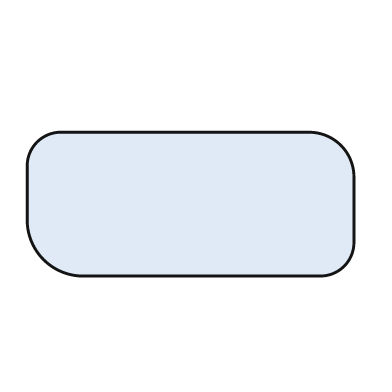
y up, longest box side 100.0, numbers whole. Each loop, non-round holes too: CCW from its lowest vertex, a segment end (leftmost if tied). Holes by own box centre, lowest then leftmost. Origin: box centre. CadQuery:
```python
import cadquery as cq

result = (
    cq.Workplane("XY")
    .moveTo(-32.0, -22.0)
    .lineTo(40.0, -22.0)
    .threePointArc((47.0, -19.0), (50.0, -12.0))
    .lineTo(50.0, 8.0)
    .threePointArc((46.0, 18.0), (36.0, 22.0))
    .lineTo(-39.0, 22.0)
    .threePointArc((-47.0, 19.0), (-50.0, 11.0))
    .lineTo(-50.0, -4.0)
    .threePointArc((-45.0, -17.0), (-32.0, -22.0))
    .close()
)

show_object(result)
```